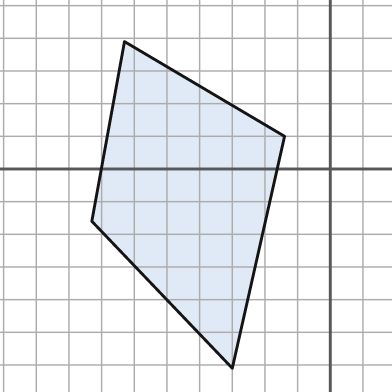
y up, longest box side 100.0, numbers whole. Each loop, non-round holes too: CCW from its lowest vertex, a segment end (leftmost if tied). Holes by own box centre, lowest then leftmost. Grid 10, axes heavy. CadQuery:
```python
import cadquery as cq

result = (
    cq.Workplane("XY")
    .moveTo(-30.0, -61.0)
    .lineTo(-14.0, 10.0)
    .lineTo(-63.0, 39.0)
    .lineTo(-73.0, -16.0)
    .close()
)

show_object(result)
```